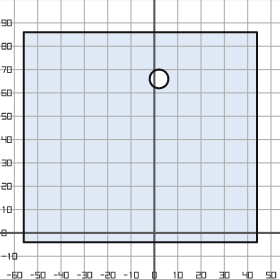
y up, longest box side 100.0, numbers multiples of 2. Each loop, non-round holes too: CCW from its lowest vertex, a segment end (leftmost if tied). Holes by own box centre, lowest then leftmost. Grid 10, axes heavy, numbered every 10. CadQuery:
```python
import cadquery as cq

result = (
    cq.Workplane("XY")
    .moveTo(-56.0, -4.0)
    .lineTo(44.0, -4.0)
    .lineTo(44.0, 86.0)
    .lineTo(-56.0, 86.0)
    .close()
    .moveTo(2.0, 66.0)
    .circle(4.0)
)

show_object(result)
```